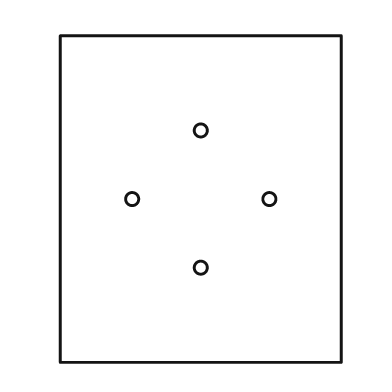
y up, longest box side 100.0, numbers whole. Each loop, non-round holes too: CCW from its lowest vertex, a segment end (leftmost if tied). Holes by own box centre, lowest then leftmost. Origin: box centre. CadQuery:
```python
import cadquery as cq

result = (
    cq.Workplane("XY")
    .moveTo(-43.0, -50.0)
    .lineTo(43.0, -50.0)
    .lineTo(43.0, 50.0)
    .lineTo(-43.0, 50.0)
    .close()
    .moveTo(0.0, -21.0)
    .circle(2.0)
    .moveTo(-21.0, 0.0)
    .circle(2.0)
    .moveTo(21.0, 0.0)
    .circle(2.0)
    .moveTo(0.0, 21.0)
    .circle(2.0)
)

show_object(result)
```